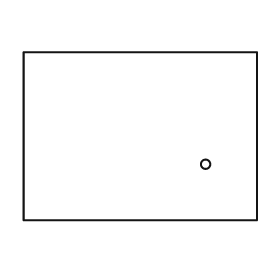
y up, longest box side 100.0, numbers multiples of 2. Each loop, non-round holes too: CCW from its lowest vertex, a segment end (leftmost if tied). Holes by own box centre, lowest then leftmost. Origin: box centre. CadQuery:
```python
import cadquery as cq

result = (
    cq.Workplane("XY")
    .moveTo(-50.0, -36.0)
    .lineTo(50.0, -36.0)
    .lineTo(50.0, 36.0)
    .lineTo(-50.0, 36.0)
    .close()
    .moveTo(28.0, -12.0)
    .circle(2.0)
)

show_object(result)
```